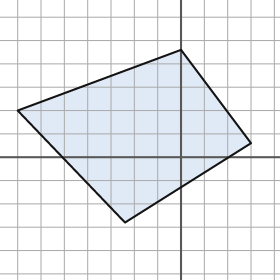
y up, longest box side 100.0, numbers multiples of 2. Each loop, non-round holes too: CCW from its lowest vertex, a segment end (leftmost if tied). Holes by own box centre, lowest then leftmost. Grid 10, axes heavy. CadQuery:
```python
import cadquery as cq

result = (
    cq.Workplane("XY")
    .moveTo(-24.0, -28.0)
    .lineTo(30.0, 6.0)
    .lineTo(0.0, 46.0)
    .lineTo(-70.0, 20.0)
    .close()
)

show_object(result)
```